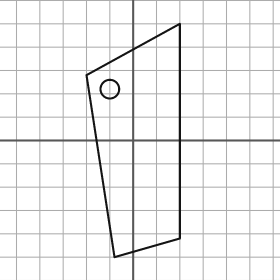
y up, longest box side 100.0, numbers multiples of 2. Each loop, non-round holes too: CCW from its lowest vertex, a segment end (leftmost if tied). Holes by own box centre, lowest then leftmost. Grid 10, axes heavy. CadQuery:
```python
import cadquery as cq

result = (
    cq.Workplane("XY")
    .moveTo(-8.0, -50.0)
    .lineTo(20.0, -42.0)
    .lineTo(20.0, 50.0)
    .lineTo(-20.0, 28.0)
    .close()
    .moveTo(-10.0, 22.0)
    .circle(4.0)
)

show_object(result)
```